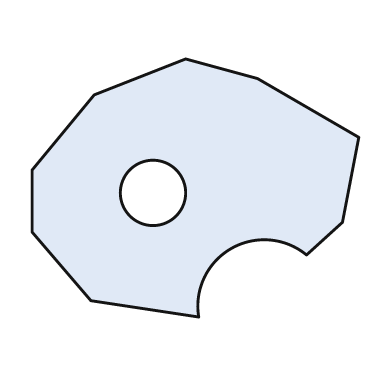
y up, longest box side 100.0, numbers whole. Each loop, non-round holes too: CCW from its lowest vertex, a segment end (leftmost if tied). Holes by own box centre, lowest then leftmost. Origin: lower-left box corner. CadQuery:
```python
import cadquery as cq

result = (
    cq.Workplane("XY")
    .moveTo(51.0, 0.0)
    .threePointArc((61.0, 21.0), (84.0, 19.0))
    .lineTo(95.0, 29.0)
    .lineTo(100.0, 55.0)
    .lineTo(69.0, 73.0)
    .lineTo(47.0, 79.0)
    .lineTo(19.0, 68.0)
    .lineTo(0.0, 45.0)
    .lineTo(0.0, 26.0)
    .lineTo(18.0, 5.0)
    .close()
    .moveTo(37.0, 38.0)
    .circle(10.0)
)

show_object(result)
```